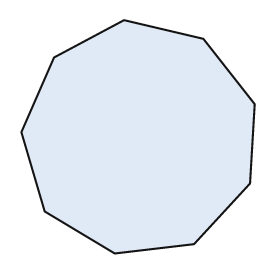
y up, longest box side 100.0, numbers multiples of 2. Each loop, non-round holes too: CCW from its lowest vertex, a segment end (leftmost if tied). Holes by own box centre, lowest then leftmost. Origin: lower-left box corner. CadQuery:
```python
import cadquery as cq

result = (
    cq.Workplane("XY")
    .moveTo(40.0, 0.0)
    .lineTo(74.0, 4.0)
    .lineTo(98.0, 30.0)
    .lineTo(100.0, 64.0)
    .lineTo(78.0, 92.0)
    .lineTo(44.0, 100.0)
    .lineTo(14.0, 84.0)
    .lineTo(0.0, 52.0)
    .lineTo(10.0, 18.0)
    .close()
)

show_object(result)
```